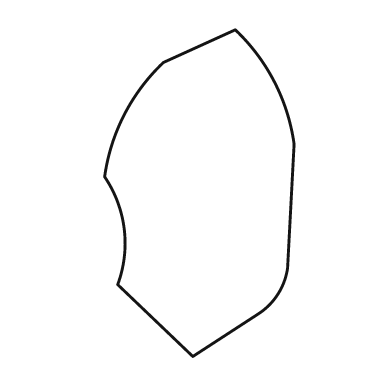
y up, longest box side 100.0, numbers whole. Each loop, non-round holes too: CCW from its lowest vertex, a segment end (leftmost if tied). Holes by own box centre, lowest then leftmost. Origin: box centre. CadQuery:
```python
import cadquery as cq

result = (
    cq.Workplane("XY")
    .moveTo(-2.0, -50.0)
    .lineTo(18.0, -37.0)
    .threePointArc((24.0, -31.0), (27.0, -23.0))
    .lineTo(29.0, 15.0)
    .threePointArc((23.0, 34.0), (11.0, 50.0))
    .lineTo(-11.0, 40.0)
    .threePointArc((-23.0, 24.0), (-29.0, 5.0))
    .threePointArc((-23.0, -11.0), (-25.0, -28.0))
    .close()
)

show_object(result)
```